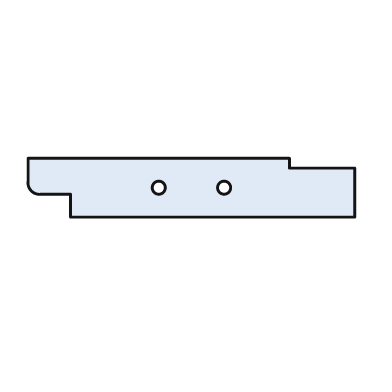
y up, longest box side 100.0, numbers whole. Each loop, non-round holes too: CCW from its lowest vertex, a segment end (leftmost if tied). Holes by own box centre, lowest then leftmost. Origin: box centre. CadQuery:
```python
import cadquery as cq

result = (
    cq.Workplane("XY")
    .moveTo(-37.0, -9.0)
    .lineTo(50.0, -9.0)
    .lineTo(50.0, 6.0)
    .lineTo(30.0, 6.0)
    .lineTo(30.0, 9.0)
    .lineTo(-50.0, 9.0)
    .lineTo(-50.0, 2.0)
    .threePointArc((-49.0, -1.0), (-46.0, -2.0))
    .lineTo(-37.0, -2.0)
    .close()
    .moveTo(-10.0, 0.0)
    .circle(2.0)
    .moveTo(10.0, 0.0)
    .circle(2.0)
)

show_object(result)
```